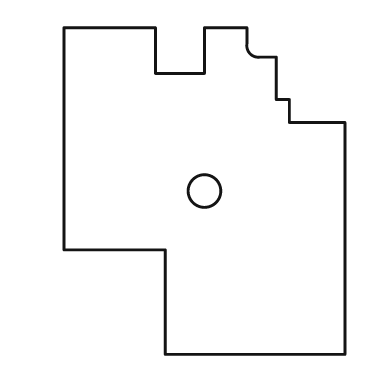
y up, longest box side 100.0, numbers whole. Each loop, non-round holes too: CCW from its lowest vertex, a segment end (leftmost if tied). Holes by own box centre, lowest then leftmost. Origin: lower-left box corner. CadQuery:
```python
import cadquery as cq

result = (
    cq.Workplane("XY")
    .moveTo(31.0, 0.0)
    .lineTo(86.0, 0.0)
    .lineTo(86.0, 71.0)
    .lineTo(69.0, 71.0)
    .lineTo(69.0, 78.0)
    .lineTo(65.0, 78.0)
    .lineTo(65.0, 91.0)
    .lineTo(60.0, 91.0)
    .threePointArc((57.0, 92.0), (56.0, 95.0))
    .lineTo(56.0, 100.0)
    .lineTo(43.0, 100.0)
    .lineTo(43.0, 86.0)
    .lineTo(28.0, 86.0)
    .lineTo(28.0, 100.0)
    .lineTo(0.0, 100.0)
    .lineTo(0.0, 32.0)
    .lineTo(31.0, 32.0)
    .close()
    .moveTo(43.0, 50.0)
    .circle(5.0)
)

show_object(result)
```